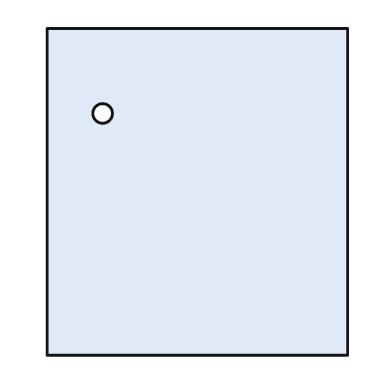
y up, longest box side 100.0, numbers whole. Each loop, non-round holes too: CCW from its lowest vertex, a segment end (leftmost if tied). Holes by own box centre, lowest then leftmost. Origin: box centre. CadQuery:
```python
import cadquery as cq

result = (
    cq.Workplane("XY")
    .moveTo(-46.0, -50.0)
    .lineTo(46.0, -50.0)
    .lineTo(46.0, 50.0)
    .lineTo(-46.0, 50.0)
    .close()
    .moveTo(-29.0, 24.0)
    .circle(3.0)
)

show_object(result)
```